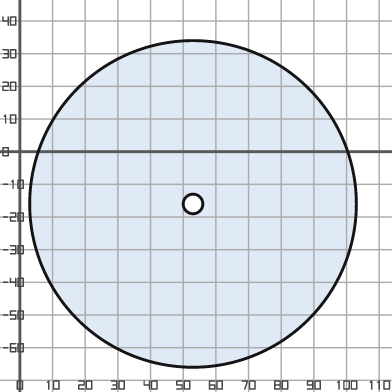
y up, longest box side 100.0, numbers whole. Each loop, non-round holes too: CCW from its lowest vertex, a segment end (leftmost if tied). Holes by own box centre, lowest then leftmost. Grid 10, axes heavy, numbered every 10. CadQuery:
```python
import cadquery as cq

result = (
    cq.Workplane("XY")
    .moveTo(53.0, -16.0)
    .circle(50.0)
    .moveTo(53.0, -16.0)
    .circle(3.0)
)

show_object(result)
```